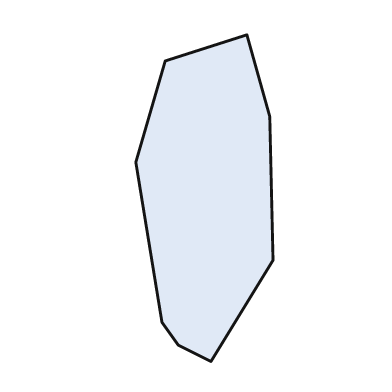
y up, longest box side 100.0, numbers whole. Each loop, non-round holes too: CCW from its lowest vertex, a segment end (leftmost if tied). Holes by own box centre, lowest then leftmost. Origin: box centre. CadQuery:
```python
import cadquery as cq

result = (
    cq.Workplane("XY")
    .moveTo(2.0, -50.0)
    .lineTo(21.0, -19.0)
    .lineTo(20.0, 25.0)
    .lineTo(13.0, 50.0)
    .lineTo(-12.0, 42.0)
    .lineTo(-21.0, 11.0)
    .lineTo(-13.0, -38.0)
    .lineTo(-8.0, -45.0)
    .close()
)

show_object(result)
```